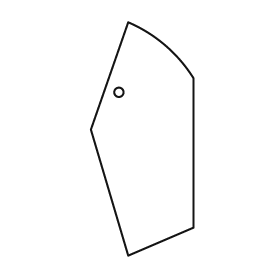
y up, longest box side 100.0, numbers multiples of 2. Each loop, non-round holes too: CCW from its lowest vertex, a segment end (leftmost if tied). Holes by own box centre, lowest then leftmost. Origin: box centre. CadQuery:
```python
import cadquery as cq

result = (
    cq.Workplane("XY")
    .moveTo(-6.0, -50.0)
    .lineTo(22.0, -38.0)
    .lineTo(22.0, 26.0)
    .threePointArc((10.0, 40.0), (-6.0, 50.0))
    .lineTo(-22.0, 4.0)
    .close()
    .moveTo(-10.0, 20.0)
    .circle(2.0)
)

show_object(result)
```